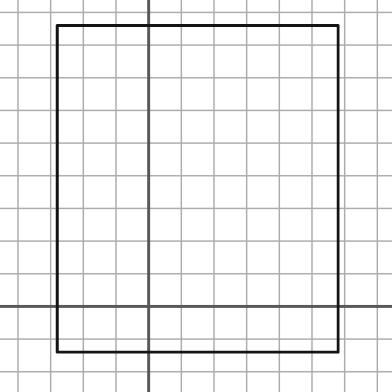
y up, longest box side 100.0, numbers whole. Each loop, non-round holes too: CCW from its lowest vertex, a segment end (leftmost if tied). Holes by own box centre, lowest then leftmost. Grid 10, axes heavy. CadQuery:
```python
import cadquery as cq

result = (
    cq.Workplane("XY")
    .moveTo(-28.0, -14.0)
    .lineTo(58.0, -14.0)
    .lineTo(58.0, 86.0)
    .lineTo(-28.0, 86.0)
    .close()
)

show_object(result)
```